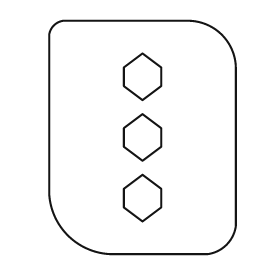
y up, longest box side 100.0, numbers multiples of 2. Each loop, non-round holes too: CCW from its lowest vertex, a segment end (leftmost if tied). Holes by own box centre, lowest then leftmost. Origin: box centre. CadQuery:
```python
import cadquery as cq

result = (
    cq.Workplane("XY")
    .moveTo(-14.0, -50.0)
    .lineTo(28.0, -50.0)
    .threePointArc((36.0, -46.0), (40.0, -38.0))
    .lineTo(40.0, 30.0)
    .threePointArc((34.0, 44.0), (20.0, 50.0))
    .lineTo(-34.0, 50.0)
    .threePointArc((-38.0, 48.0), (-40.0, 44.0))
    .lineTo(-40.0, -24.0)
    .threePointArc((-32.0, -42.0), (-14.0, -50.0))
    .close()
    .moveTo(0.0, -36.0)
    .lineTo(8.0, -30.0)
    .lineTo(8.0, -22.0)
    .lineTo(0.0, -16.0)
    .lineTo(-8.0, -22.0)
    .lineTo(-8.0, -30.0)
    .close()
    .moveTo(0.0, -10.0)
    .lineTo(8.0, -4.0)
    .lineTo(8.0, 4.0)
    .lineTo(0.0, 10.0)
    .lineTo(-8.0, 4.0)
    .lineTo(-8.0, -4.0)
    .close()
    .moveTo(0.0, 16.0)
    .lineTo(8.0, 22.0)
    .lineTo(8.0, 30.0)
    .lineTo(0.0, 36.0)
    .lineTo(-8.0, 30.0)
    .lineTo(-8.0, 22.0)
    .close()
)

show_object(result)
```